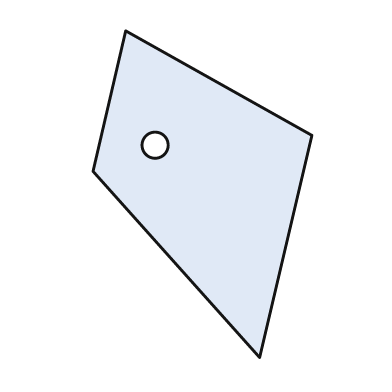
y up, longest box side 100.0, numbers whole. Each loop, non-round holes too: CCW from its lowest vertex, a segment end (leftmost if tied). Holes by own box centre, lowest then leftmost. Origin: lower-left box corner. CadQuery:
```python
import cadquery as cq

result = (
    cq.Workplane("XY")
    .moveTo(51.0, 0.0)
    .lineTo(67.0, 68.0)
    .lineTo(10.0, 100.0)
    .lineTo(0.0, 57.0)
    .close()
    .moveTo(19.0, 65.0)
    .circle(4.0)
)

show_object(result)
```